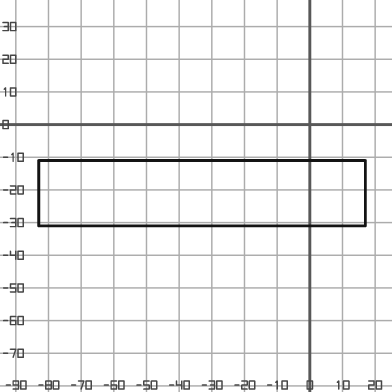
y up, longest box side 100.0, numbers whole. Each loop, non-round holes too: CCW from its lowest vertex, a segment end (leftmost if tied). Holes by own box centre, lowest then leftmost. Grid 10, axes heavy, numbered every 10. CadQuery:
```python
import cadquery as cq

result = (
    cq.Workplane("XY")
    .moveTo(-83.0, -31.0)
    .lineTo(17.0, -31.0)
    .lineTo(17.0, -11.0)
    .lineTo(-83.0, -11.0)
    .close()
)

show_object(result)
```